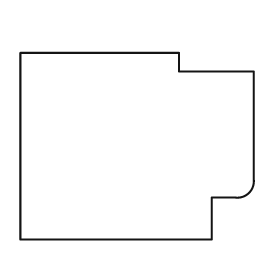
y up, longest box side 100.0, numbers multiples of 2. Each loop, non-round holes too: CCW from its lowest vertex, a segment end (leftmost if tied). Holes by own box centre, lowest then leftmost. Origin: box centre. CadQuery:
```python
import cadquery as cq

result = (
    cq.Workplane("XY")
    .moveTo(-50.0, -40.0)
    .lineTo(32.0, -40.0)
    .lineTo(32.0, -22.0)
    .lineTo(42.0, -22.0)
    .threePointArc((48.0, -20.0), (50.0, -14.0))
    .lineTo(50.0, 32.0)
    .lineTo(18.0, 32.0)
    .lineTo(18.0, 40.0)
    .lineTo(-50.0, 40.0)
    .close()
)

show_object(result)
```